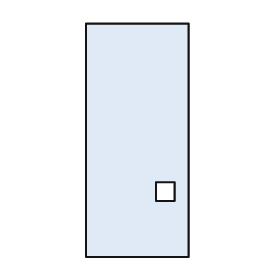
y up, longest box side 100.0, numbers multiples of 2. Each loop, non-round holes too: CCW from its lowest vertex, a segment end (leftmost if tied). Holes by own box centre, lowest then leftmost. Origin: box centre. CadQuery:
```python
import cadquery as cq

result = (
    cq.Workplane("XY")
    .moveTo(-22.0, -50.0)
    .lineTo(22.0, -50.0)
    .lineTo(22.0, 50.0)
    .lineTo(-22.0, 50.0)
    .close()
    .moveTo(8.0, -26.0)
    .lineTo(16.0, -26.0)
    .lineTo(16.0, -18.0)
    .lineTo(8.0, -18.0)
    .close()
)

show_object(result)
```